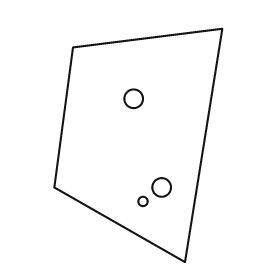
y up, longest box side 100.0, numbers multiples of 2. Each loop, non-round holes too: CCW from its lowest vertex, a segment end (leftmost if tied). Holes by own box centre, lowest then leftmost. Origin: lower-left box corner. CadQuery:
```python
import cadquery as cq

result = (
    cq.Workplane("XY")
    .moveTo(56.0, 0.0)
    .lineTo(72.0, 100.0)
    .lineTo(8.0, 92.0)
    .lineTo(0.0, 32.0)
    .close()
    .moveTo(38.0, 26.0)
    .circle(2.0)
    .moveTo(46.0, 32.0)
    .circle(4.0)
    .moveTo(34.0, 70.0)
    .circle(4.0)
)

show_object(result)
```